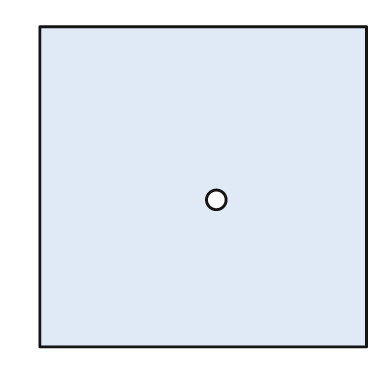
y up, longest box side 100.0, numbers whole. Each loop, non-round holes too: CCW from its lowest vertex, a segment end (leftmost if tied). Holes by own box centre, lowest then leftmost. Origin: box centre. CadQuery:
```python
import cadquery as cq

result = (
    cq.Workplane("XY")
    .moveTo(-50.0, -49.0)
    .lineTo(50.0, -49.0)
    .lineTo(50.0, 49.0)
    .lineTo(-50.0, 49.0)
    .close()
    .moveTo(4.0, -4.0)
    .circle(3.0)
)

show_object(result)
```